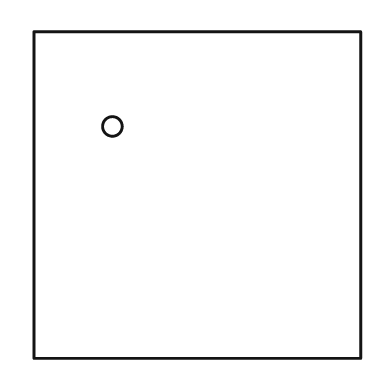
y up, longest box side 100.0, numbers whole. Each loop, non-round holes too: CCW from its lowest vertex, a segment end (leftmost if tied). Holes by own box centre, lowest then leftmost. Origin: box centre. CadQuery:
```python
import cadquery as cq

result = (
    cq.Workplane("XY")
    .moveTo(-50.0, -50.0)
    .lineTo(50.0, -50.0)
    .lineTo(50.0, 50.0)
    .lineTo(-50.0, 50.0)
    .close()
    .moveTo(-26.0, 21.0)
    .circle(3.0)
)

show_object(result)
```